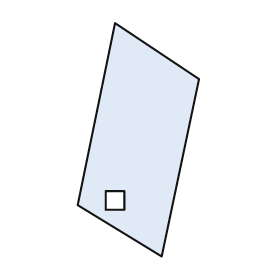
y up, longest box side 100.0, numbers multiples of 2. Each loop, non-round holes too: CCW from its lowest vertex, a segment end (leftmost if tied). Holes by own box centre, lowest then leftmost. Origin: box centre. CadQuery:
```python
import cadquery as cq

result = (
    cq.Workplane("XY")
    .moveTo(10.0, -50.0)
    .lineTo(26.0, 26.0)
    .lineTo(-10.0, 50.0)
    .lineTo(-26.0, -28.0)
    .close()
    .moveTo(-14.0, -30.0)
    .lineTo(-6.0, -30.0)
    .lineTo(-6.0, -22.0)
    .lineTo(-14.0, -22.0)
    .close()
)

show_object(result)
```